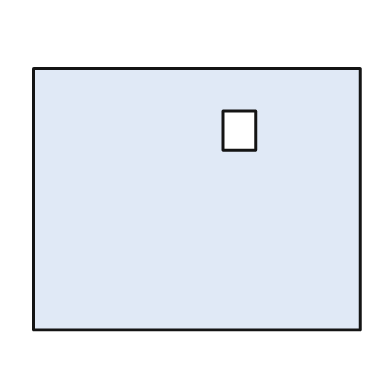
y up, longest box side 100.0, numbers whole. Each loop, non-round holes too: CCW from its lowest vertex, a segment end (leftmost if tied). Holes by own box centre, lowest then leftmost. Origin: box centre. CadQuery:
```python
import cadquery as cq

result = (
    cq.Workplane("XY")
    .moveTo(-50.0, -40.0)
    .lineTo(50.0, -40.0)
    .lineTo(50.0, 40.0)
    .lineTo(-50.0, 40.0)
    .close()
    .moveTo(8.0, 15.0)
    .lineTo(18.0, 15.0)
    .lineTo(18.0, 27.0)
    .lineTo(8.0, 27.0)
    .close()
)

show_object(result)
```